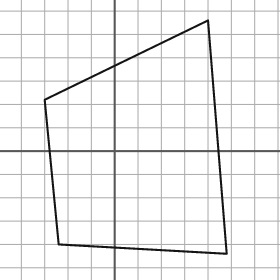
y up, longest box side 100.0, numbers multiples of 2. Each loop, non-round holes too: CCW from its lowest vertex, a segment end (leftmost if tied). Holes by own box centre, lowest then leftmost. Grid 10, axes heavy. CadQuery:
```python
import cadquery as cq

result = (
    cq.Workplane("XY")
    .moveTo(48.0, -44.0)
    .lineTo(40.0, 56.0)
    .lineTo(-30.0, 22.0)
    .lineTo(-24.0, -40.0)
    .close()
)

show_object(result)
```